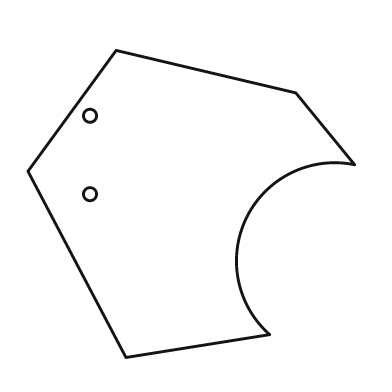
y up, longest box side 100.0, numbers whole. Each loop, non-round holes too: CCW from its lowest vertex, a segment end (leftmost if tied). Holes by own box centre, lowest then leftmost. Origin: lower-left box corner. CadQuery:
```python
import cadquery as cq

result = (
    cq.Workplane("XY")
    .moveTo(30.0, 0.0)
    .lineTo(74.0, 7.0)
    .threePointArc((67.0, 43.0), (100.0, 59.0))
    .lineTo(82.0, 81.0)
    .lineTo(27.0, 94.0)
    .lineTo(0.0, 57.0)
    .close()
    .moveTo(19.0, 50.0)
    .circle(2.0)
    .moveTo(19.0, 74.0)
    .circle(2.0)
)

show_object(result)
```